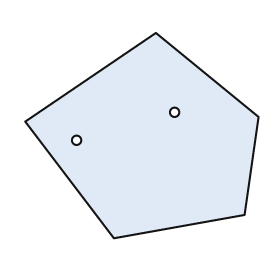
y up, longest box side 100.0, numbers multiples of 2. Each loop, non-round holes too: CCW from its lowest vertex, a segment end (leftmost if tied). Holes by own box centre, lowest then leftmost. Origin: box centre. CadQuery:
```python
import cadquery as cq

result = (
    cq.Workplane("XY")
    .moveTo(-12.0, -44.0)
    .lineTo(44.0, -34.0)
    .lineTo(50.0, 8.0)
    .lineTo(6.0, 44.0)
    .lineTo(-50.0, 6.0)
    .close()
    .moveTo(-28.0, -2.0)
    .circle(2.0)
    .moveTo(14.0, 10.0)
    .circle(2.0)
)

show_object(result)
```